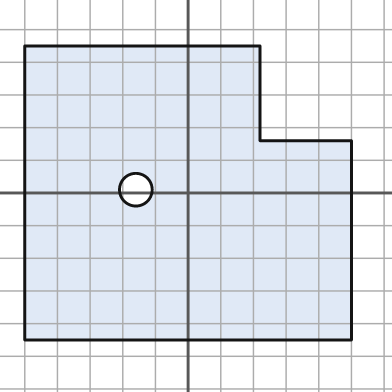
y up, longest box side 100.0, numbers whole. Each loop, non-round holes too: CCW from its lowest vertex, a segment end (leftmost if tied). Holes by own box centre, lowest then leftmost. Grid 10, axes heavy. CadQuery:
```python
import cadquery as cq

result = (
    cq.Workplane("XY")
    .moveTo(-50.0, -45.0)
    .lineTo(50.0, -45.0)
    .lineTo(50.0, 16.0)
    .lineTo(22.0, 16.0)
    .lineTo(22.0, 45.0)
    .lineTo(-50.0, 45.0)
    .close()
    .moveTo(-16.0, 1.0)
    .circle(5.0)
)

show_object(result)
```